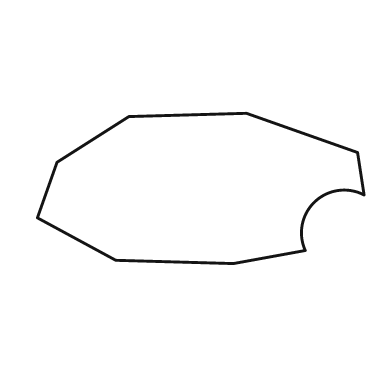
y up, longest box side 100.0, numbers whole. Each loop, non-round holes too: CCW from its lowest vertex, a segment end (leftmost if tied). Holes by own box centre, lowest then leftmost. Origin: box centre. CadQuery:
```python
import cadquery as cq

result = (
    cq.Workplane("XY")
    .moveTo(10.0, -23.0)
    .lineTo(32.0, -19.0)
    .threePointArc((35.0, -4.0), (50.0, -2.0))
    .lineTo(48.0, 11.0)
    .lineTo(14.0, 23.0)
    .lineTo(-22.0, 22.0)
    .lineTo(-44.0, 8.0)
    .lineTo(-50.0, -9.0)
    .lineTo(-26.0, -22.0)
    .close()
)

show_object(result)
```